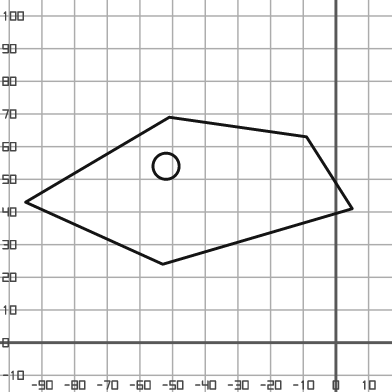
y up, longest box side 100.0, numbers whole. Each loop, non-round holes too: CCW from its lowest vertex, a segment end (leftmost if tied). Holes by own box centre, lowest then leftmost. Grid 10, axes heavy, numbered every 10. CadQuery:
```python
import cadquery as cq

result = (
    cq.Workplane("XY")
    .moveTo(-53.0, 24.0)
    .lineTo(5.0, 41.0)
    .lineTo(-9.0, 63.0)
    .lineTo(-51.0, 69.0)
    .lineTo(-95.0, 43.0)
    .close()
    .moveTo(-52.0, 54.0)
    .circle(4.0)
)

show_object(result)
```